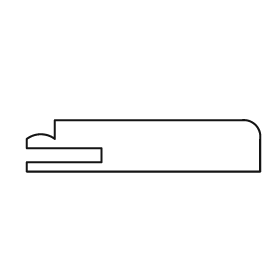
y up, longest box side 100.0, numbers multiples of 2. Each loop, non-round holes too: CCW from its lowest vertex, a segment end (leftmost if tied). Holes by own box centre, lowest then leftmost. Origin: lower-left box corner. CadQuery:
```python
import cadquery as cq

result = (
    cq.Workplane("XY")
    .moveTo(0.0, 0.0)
    .lineTo(100.0, 0.0)
    .lineTo(100.0, 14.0)
    .threePointArc((98.0, 20.0), (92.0, 22.0))
    .lineTo(12.0, 22.0)
    .lineTo(12.0, 14.0)
    .threePointArc((6.0, 16.0), (0.0, 14.0))
    .lineTo(0.0, 10.0)
    .lineTo(32.0, 10.0)
    .lineTo(32.0, 4.0)
    .lineTo(0.0, 4.0)
    .close()
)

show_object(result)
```